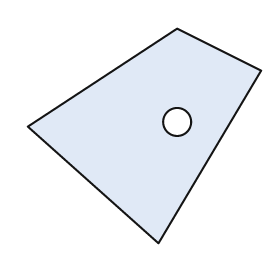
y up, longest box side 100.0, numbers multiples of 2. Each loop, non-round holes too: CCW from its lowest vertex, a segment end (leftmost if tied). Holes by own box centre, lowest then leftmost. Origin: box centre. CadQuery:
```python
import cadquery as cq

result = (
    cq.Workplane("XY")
    .moveTo(6.0, -46.0)
    .lineTo(50.0, 28.0)
    .lineTo(14.0, 46.0)
    .lineTo(-50.0, 4.0)
    .close()
    .moveTo(14.0, 6.0)
    .circle(6.0)
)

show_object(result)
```